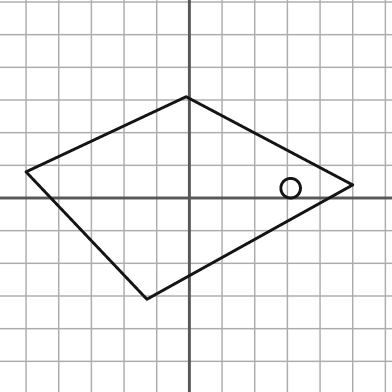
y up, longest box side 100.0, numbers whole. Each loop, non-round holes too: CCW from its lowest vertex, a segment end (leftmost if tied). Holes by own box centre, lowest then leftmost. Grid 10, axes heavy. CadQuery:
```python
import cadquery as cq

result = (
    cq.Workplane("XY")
    .moveTo(-13.0, -31.0)
    .lineTo(50.0, 4.0)
    .lineTo(-1.0, 31.0)
    .lineTo(-50.0, 8.0)
    .close()
    .moveTo(31.0, 3.0)
    .circle(3.0)
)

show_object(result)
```